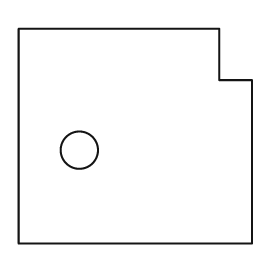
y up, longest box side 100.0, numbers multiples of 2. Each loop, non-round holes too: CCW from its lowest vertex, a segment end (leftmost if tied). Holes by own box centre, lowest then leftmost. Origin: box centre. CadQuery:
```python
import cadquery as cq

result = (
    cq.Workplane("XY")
    .moveTo(-50.0, -46.0)
    .lineTo(50.0, -46.0)
    .lineTo(50.0, 24.0)
    .lineTo(36.0, 24.0)
    .lineTo(36.0, 46.0)
    .lineTo(-50.0, 46.0)
    .close()
    .moveTo(-24.0, -6.0)
    .circle(8.0)
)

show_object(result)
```